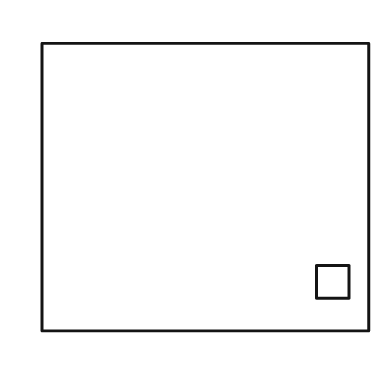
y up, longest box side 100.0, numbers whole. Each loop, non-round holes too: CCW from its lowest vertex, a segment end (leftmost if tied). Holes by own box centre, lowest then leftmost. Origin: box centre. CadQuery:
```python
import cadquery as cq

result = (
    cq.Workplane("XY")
    .moveTo(-50.0, -44.0)
    .lineTo(50.0, -44.0)
    .lineTo(50.0, 44.0)
    .lineTo(-50.0, 44.0)
    .close()
    .moveTo(34.0, -34.0)
    .lineTo(44.0, -34.0)
    .lineTo(44.0, -24.0)
    .lineTo(34.0, -24.0)
    .close()
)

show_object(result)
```